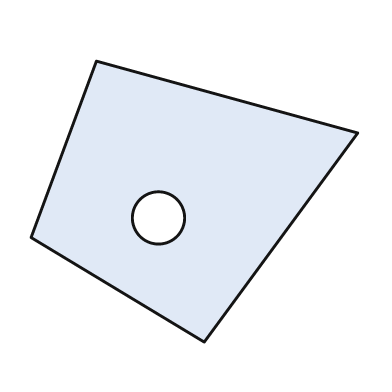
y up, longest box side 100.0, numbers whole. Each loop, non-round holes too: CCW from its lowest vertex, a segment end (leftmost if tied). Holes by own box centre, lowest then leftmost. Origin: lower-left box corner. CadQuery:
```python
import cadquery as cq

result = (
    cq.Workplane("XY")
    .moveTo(53.0, 0.0)
    .lineTo(100.0, 64.0)
    .lineTo(20.0, 86.0)
    .lineTo(0.0, 32.0)
    .close()
    .moveTo(39.0, 38.0)
    .circle(8.0)
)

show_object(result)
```